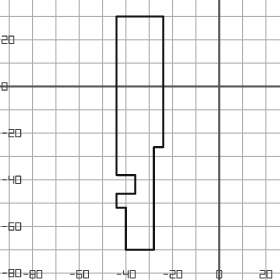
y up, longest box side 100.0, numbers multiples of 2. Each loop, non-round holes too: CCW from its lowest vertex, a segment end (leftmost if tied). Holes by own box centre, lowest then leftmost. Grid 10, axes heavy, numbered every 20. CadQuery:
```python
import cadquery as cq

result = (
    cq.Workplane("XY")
    .moveTo(-40.0, -70.0)
    .lineTo(-28.0, -70.0)
    .lineTo(-28.0, -26.0)
    .lineTo(-24.0, -26.0)
    .lineTo(-24.0, 30.0)
    .lineTo(-44.0, 30.0)
    .lineTo(-44.0, -38.0)
    .lineTo(-36.0, -38.0)
    .lineTo(-36.0, -46.0)
    .lineTo(-44.0, -46.0)
    .lineTo(-44.0, -52.0)
    .lineTo(-40.0, -52.0)
    .close()
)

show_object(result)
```